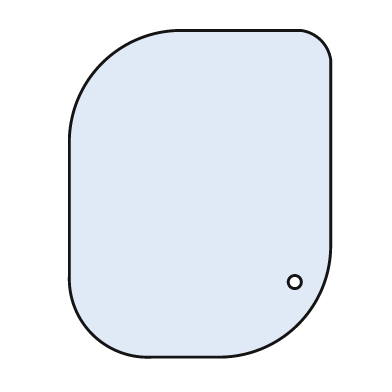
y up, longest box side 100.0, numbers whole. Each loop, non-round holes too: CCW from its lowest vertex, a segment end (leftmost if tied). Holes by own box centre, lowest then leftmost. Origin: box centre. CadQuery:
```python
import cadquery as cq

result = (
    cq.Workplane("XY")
    .moveTo(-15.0, -50.0)
    .lineTo(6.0, -50.0)
    .threePointArc((30.0, -40.0), (40.0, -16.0))
    .lineTo(40.0, 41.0)
    .threePointArc((37.0, 47.0), (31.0, 50.0))
    .lineTo(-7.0, 50.0)
    .threePointArc((-30.0, 40.0), (-40.0, 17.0))
    .lineTo(-40.0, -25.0)
    .threePointArc((-33.0, -43.0), (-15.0, -50.0))
    .close()
    .moveTo(29.0, -27.0)
    .circle(2.0)
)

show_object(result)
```